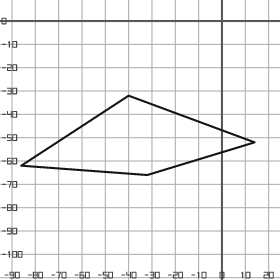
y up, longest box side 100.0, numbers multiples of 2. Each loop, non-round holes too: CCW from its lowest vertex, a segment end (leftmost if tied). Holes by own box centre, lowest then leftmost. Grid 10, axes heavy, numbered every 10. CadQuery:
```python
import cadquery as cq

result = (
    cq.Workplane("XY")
    .moveTo(-32.0, -66.0)
    .lineTo(14.0, -52.0)
    .lineTo(-40.0, -32.0)
    .lineTo(-86.0, -62.0)
    .close()
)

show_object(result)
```